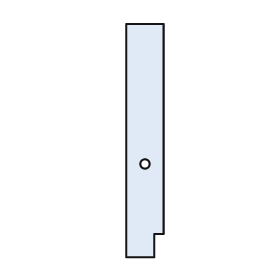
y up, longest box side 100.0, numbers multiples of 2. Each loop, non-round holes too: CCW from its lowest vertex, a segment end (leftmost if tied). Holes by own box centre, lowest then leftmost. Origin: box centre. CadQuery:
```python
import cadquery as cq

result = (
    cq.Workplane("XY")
    .moveTo(-8.0, -50.0)
    .lineTo(4.0, -50.0)
    .lineTo(4.0, -40.0)
    .lineTo(8.0, -40.0)
    .lineTo(8.0, 50.0)
    .lineTo(-8.0, 50.0)
    .close()
    .moveTo(0.0, -10.0)
    .circle(2.0)
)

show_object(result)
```